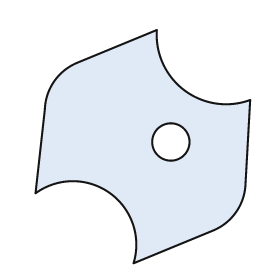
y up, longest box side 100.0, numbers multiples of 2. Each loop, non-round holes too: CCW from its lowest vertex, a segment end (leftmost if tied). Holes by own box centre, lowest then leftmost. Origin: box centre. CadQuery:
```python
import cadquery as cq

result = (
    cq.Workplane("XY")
    .moveTo(-4.0, -50.0)
    .lineTo(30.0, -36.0)
    .threePointArc((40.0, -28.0), (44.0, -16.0))
    .lineTo(46.0, 20.0)
    .threePointArc((18.0, 24.0), (6.0, 50.0))
    .lineTo(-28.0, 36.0)
    .threePointArc((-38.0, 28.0), (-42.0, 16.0))
    .lineTo(-46.0, -20.0)
    .threePointArc((-14.0, -20.0), (-4.0, -50.0))
    .close()
    .moveTo(12.0, 2.0)
    .circle(8.0)
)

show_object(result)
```